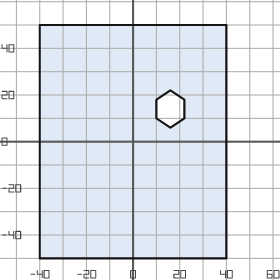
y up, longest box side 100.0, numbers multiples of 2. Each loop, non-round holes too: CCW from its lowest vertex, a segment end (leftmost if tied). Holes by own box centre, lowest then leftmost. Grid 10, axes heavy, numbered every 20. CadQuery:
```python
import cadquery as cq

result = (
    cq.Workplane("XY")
    .moveTo(-40.0, -50.0)
    .lineTo(40.0, -50.0)
    .lineTo(40.0, 50.0)
    .lineTo(-40.0, 50.0)
    .close()
    .moveTo(16.0, 6.0)
    .lineTo(22.0, 10.0)
    .lineTo(22.0, 18.0)
    .lineTo(16.0, 22.0)
    .lineTo(10.0, 18.0)
    .lineTo(10.0, 10.0)
    .close()
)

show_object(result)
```